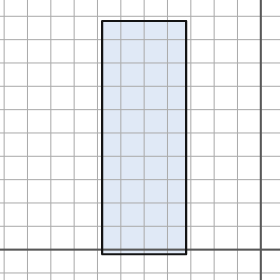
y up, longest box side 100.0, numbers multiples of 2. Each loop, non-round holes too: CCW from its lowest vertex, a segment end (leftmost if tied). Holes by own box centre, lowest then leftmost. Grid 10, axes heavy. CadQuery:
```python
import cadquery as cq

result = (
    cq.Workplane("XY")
    .moveTo(-68.0, -2.0)
    .lineTo(-32.0, -2.0)
    .lineTo(-32.0, 98.0)
    .lineTo(-68.0, 98.0)
    .close()
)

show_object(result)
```